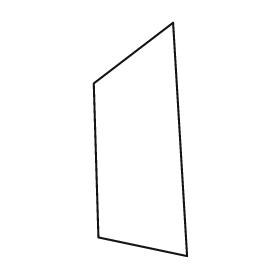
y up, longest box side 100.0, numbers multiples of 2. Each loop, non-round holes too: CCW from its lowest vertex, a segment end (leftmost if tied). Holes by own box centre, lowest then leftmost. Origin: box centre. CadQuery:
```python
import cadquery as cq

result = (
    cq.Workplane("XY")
    .moveTo(20.0, -50.0)
    .lineTo(14.0, 50.0)
    .lineTo(-20.0, 24.0)
    .lineTo(-18.0, -42.0)
    .close()
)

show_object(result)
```